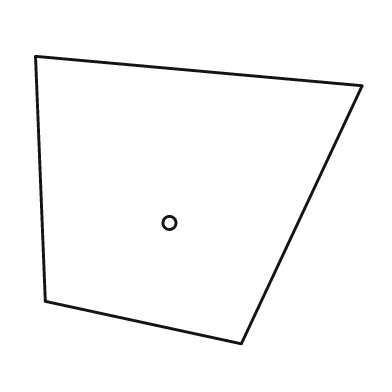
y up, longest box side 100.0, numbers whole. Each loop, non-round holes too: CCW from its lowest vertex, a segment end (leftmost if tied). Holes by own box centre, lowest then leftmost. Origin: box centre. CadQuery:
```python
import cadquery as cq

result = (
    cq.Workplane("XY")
    .moveTo(13.0, -44.0)
    .lineTo(50.0, 35.0)
    .lineTo(-50.0, 44.0)
    .lineTo(-47.0, -31.0)
    .close()
    .moveTo(-9.0, -7.0)
    .circle(2.0)
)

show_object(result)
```